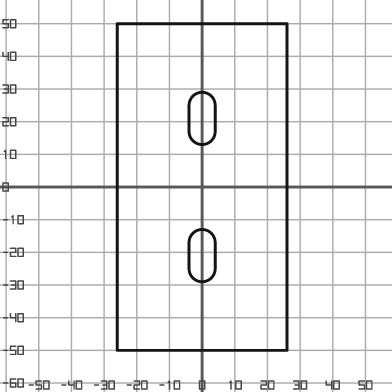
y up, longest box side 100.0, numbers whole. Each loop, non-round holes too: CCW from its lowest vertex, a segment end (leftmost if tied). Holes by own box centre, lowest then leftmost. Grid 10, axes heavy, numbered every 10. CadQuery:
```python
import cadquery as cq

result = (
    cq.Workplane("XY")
    .moveTo(-26.0, -50.0)
    .lineTo(26.0, -50.0)
    .lineTo(26.0, 50.0)
    .lineTo(-26.0, 50.0)
    .close()
    .moveTo(-4.0, -25.0)
    .threePointArc((0.0, -29.0), (4.0, -25.0))
    .lineTo(4.0, -17.0)
    .threePointArc((0.0, -13.0), (-4.0, -17.0))
    .close()
    .moveTo(-4.0, 17.0)
    .threePointArc((0.0, 13.0), (4.0, 17.0))
    .lineTo(4.0, 25.0)
    .threePointArc((0.0, 29.0), (-4.0, 25.0))
    .close()
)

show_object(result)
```